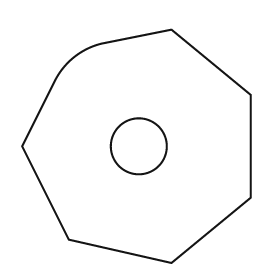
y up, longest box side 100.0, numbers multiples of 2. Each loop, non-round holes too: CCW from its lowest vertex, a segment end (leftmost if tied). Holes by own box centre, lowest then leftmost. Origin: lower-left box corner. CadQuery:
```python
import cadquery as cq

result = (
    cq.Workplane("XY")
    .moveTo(64.0, 0.0)
    .lineTo(98.0, 28.0)
    .lineTo(98.0, 72.0)
    .lineTo(64.0, 100.0)
    .lineTo(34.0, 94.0)
    .threePointArc((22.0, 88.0), (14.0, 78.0))
    .lineTo(0.0, 50.0)
    .lineTo(20.0, 10.0)
    .close()
    .moveTo(50.0, 50.0)
    .circle(12.0)
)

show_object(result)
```